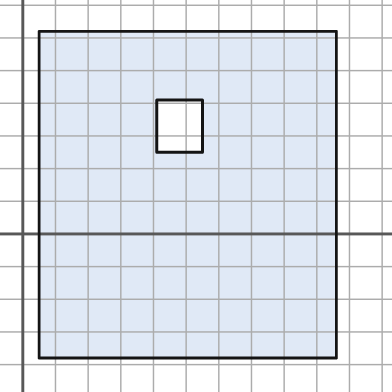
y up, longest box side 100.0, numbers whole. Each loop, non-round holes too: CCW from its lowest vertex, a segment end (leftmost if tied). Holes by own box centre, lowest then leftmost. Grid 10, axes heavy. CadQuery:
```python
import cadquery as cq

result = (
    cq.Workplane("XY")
    .moveTo(5.0, -38.0)
    .lineTo(96.0, -38.0)
    .lineTo(96.0, 62.0)
    .lineTo(5.0, 62.0)
    .close()
    .moveTo(41.0, 25.0)
    .lineTo(55.0, 25.0)
    .lineTo(55.0, 41.0)
    .lineTo(41.0, 41.0)
    .close()
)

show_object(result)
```